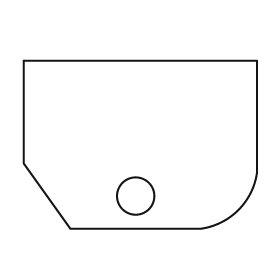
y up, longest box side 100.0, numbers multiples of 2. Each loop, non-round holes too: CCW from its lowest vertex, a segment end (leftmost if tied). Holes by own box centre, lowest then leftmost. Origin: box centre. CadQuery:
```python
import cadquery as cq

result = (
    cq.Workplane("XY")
    .moveTo(-30.0, -36.0)
    .lineTo(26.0, -36.0)
    .threePointArc((42.0, -28.0), (50.0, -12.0))
    .lineTo(50.0, 36.0)
    .lineTo(-50.0, 36.0)
    .lineTo(-50.0, -8.0)
    .close()
    .moveTo(-2.0, -22.0)
    .circle(8.0)
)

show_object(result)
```